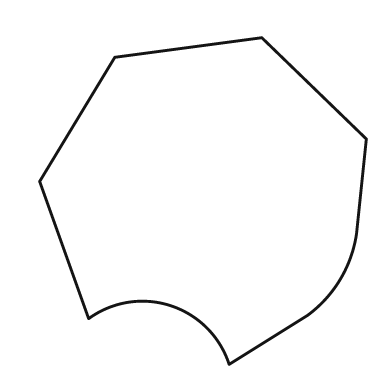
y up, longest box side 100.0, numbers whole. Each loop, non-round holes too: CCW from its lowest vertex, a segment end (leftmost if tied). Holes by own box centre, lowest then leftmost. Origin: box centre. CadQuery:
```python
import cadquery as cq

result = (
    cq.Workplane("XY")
    .moveTo(8.0, -50.0)
    .lineTo(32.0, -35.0)
    .threePointArc((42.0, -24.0), (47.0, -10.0))
    .lineTo(50.0, 19.0)
    .lineTo(18.0, 50.0)
    .lineTo(-27.0, 44.0)
    .lineTo(-50.0, 6.0)
    .lineTo(-35.0, -36.0)
    .threePointArc((-10.0, -32.0), (8.0, -50.0))
    .close()
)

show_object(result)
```